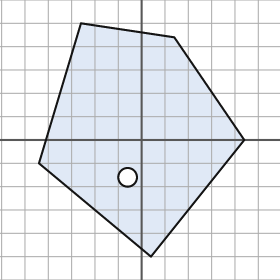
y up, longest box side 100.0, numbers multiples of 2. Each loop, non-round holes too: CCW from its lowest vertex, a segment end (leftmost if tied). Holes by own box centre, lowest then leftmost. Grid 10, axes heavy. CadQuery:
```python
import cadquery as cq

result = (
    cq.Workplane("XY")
    .moveTo(4.0, -50.0)
    .lineTo(44.0, 0.0)
    .lineTo(14.0, 44.0)
    .lineTo(-26.0, 50.0)
    .lineTo(-44.0, -10.0)
    .close()
    .moveTo(-6.0, -16.0)
    .circle(4.0)
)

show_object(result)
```